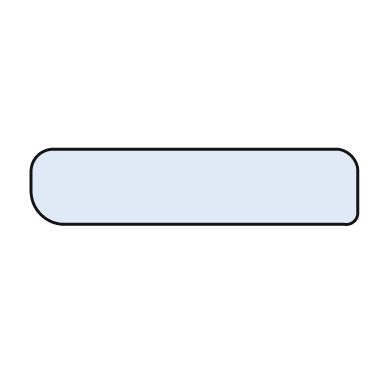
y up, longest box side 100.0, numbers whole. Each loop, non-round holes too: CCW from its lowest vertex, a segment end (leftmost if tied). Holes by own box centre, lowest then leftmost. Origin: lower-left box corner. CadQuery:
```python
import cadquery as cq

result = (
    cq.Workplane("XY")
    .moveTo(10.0, 0.0)
    .lineTo(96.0, 0.0)
    .threePointArc((99.0, 1.0), (100.0, 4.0))
    .lineTo(100.0, 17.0)
    .threePointArc((98.0, 21.0), (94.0, 23.0))
    .lineTo(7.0, 23.0)
    .threePointArc((2.0, 21.0), (0.0, 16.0))
    .lineTo(0.0, 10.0)
    .threePointArc((3.0, 3.0), (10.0, 0.0))
    .close()
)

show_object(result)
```